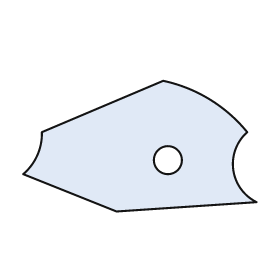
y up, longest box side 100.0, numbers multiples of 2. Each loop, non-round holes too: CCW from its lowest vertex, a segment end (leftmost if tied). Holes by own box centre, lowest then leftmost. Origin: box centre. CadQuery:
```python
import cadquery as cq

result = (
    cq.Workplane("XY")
    .moveTo(-10.0, -28.0)
    .lineTo(50.0, -24.0)
    .threePointArc((40.0, -10.0), (46.0, 6.0))
    .threePointArc((30.0, 20.0), (10.0, 28.0))
    .lineTo(-42.0, 6.0)
    .threePointArc((-44.0, -4.0), (-50.0, -12.0))
    .close()
    .moveTo(12.0, -6.0)
    .circle(6.0)
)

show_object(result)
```